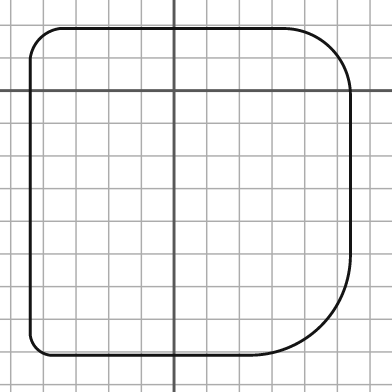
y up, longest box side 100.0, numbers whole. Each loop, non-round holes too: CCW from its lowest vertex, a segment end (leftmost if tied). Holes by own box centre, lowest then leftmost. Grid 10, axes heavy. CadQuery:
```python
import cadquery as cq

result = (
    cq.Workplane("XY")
    .moveTo(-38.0, -81.0)
    .lineTo(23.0, -81.0)
    .threePointArc((45.0, -72.0), (54.0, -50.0))
    .lineTo(54.0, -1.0)
    .threePointArc((48.0, 13.0), (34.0, 19.0))
    .lineTo(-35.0, 19.0)
    .threePointArc((-41.0, 16.0), (-44.0, 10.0))
    .lineTo(-44.0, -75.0)
    .threePointArc((-42.0, -79.0), (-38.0, -81.0))
    .close()
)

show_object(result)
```